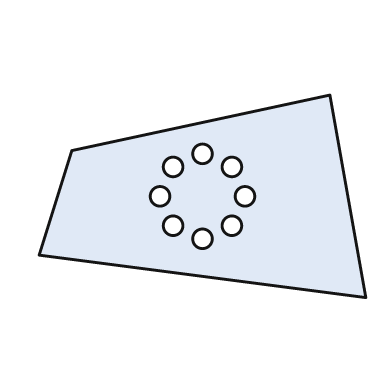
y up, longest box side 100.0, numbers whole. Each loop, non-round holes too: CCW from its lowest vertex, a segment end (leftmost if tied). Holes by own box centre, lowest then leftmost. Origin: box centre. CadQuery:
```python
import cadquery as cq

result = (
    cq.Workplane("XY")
    .moveTo(50.0, -31.0)
    .lineTo(39.0, 31.0)
    .lineTo(-40.0, 14.0)
    .lineTo(-50.0, -18.0)
    .close()
    .moveTo(0.0, -13.0)
    .circle(3.0)
    .moveTo(-9.0, -9.0)
    .circle(3.0)
    .moveTo(9.0, -9.0)
    .circle(3.0)
    .moveTo(-13.0, 0.0)
    .circle(3.0)
    .moveTo(13.0, 0.0)
    .circle(3.0)
    .moveTo(-9.0, 9.0)
    .circle(3.0)
    .moveTo(9.0, 9.0)
    .circle(3.0)
    .moveTo(0.0, 13.0)
    .circle(3.0)
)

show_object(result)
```